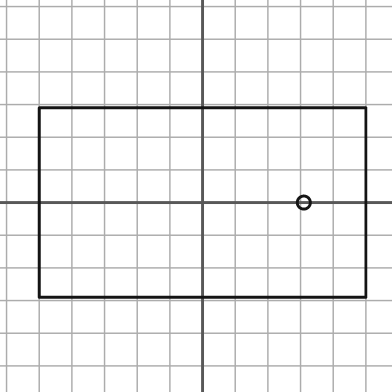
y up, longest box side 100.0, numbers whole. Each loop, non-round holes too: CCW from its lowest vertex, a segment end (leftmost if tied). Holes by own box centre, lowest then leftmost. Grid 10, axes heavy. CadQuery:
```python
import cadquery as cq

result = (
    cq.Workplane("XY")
    .moveTo(-50.0, -29.0)
    .lineTo(50.0, -29.0)
    .lineTo(50.0, 29.0)
    .lineTo(-50.0, 29.0)
    .close()
    .moveTo(31.0, 0.0)
    .circle(2.0)
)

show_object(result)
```